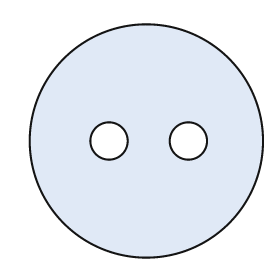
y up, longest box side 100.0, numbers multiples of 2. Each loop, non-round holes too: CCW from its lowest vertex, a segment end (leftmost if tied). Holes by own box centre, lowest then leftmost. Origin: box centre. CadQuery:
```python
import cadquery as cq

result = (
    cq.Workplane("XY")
    .moveTo(0.0, 0.0)
    .circle(50.0)
    .moveTo(-16.0, 0.0)
    .circle(8.0)
    .moveTo(18.0, 0.0)
    .circle(8.0)
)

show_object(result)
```